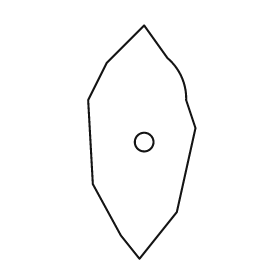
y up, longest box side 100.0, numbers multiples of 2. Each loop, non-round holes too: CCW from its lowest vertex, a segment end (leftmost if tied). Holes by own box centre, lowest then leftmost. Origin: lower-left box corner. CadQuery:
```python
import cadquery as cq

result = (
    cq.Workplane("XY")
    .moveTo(22.0, 0.0)
    .lineTo(38.0, 20.0)
    .lineTo(46.0, 56.0)
    .lineTo(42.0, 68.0)
    .threePointArc((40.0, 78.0), (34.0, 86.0))
    .lineTo(24.0, 100.0)
    .lineTo(8.0, 84.0)
    .lineTo(0.0, 68.0)
    .lineTo(2.0, 32.0)
    .lineTo(14.0, 10.0)
    .close()
    .moveTo(24.0, 50.0)
    .circle(4.0)
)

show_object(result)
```